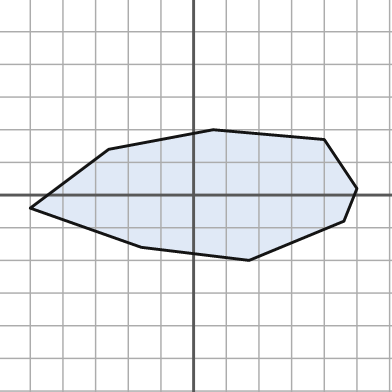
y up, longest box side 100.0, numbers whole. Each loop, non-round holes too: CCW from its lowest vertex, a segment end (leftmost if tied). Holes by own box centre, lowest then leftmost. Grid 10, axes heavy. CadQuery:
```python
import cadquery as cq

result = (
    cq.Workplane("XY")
    .moveTo(17.0, -20.0)
    .lineTo(46.0, -8.0)
    .lineTo(50.0, 2.0)
    .lineTo(40.0, 17.0)
    .lineTo(6.0, 20.0)
    .lineTo(-26.0, 14.0)
    .lineTo(-50.0, -4.0)
    .lineTo(-16.0, -16.0)
    .close()
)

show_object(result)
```